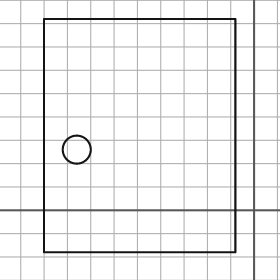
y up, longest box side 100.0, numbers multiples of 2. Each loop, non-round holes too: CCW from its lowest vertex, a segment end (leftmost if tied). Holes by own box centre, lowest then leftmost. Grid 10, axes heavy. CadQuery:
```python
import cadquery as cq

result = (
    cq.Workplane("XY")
    .moveTo(-90.0, -18.0)
    .lineTo(-8.0, -18.0)
    .lineTo(-8.0, 82.0)
    .lineTo(-90.0, 82.0)
    .close()
    .moveTo(-76.0, 26.0)
    .circle(6.0)
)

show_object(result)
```